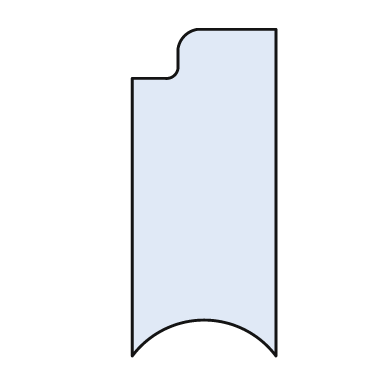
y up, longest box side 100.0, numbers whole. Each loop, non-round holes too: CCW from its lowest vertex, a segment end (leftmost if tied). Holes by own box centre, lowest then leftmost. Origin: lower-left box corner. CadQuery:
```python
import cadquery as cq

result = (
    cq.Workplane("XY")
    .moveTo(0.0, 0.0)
    .threePointArc((22.0, 11.0), (44.0, 0.0))
    .lineTo(44.0, 100.0)
    .lineTo(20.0, 100.0)
    .threePointArc((16.0, 98.0), (14.0, 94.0))
    .lineTo(14.0, 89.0)
    .threePointArc((13.0, 86.0), (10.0, 85.0))
    .lineTo(0.0, 85.0)
    .close()
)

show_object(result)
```